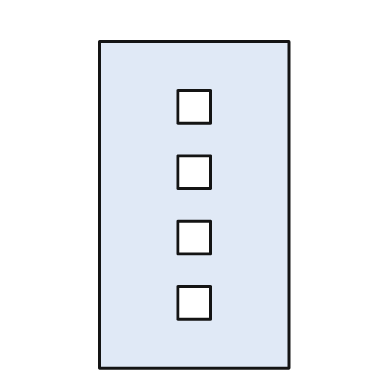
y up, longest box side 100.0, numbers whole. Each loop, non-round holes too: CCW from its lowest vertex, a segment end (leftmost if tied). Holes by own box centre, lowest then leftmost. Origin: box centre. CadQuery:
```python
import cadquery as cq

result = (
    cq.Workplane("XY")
    .moveTo(-29.0, -50.0)
    .lineTo(29.0, -50.0)
    .lineTo(29.0, 50.0)
    .lineTo(-29.0, 50.0)
    .close()
    .moveTo(-5.0, -35.0)
    .lineTo(5.0, -35.0)
    .lineTo(5.0, -25.0)
    .lineTo(-5.0, -25.0)
    .close()
    .moveTo(-5.0, -15.0)
    .lineTo(5.0, -15.0)
    .lineTo(5.0, -5.0)
    .lineTo(-5.0, -5.0)
    .close()
    .moveTo(-5.0, 5.0)
    .lineTo(5.0, 5.0)
    .lineTo(5.0, 15.0)
    .lineTo(-5.0, 15.0)
    .close()
    .moveTo(-5.0, 25.0)
    .lineTo(5.0, 25.0)
    .lineTo(5.0, 35.0)
    .lineTo(-5.0, 35.0)
    .close()
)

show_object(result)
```